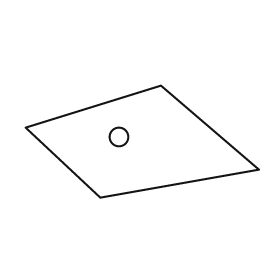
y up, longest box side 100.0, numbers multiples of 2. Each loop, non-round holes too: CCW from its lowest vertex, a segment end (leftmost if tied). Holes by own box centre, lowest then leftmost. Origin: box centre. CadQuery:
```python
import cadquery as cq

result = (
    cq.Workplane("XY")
    .moveTo(-18.0, -24.0)
    .lineTo(50.0, -12.0)
    .lineTo(8.0, 24.0)
    .lineTo(-50.0, 6.0)
    .close()
    .moveTo(-10.0, 2.0)
    .circle(4.0)
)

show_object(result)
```